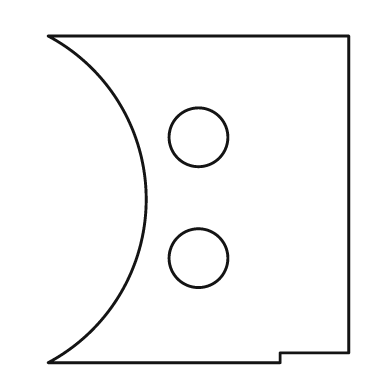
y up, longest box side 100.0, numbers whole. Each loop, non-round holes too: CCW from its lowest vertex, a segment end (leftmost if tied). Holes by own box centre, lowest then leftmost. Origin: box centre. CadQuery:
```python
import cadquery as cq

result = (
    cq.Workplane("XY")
    .moveTo(-46.0, -50.0)
    .lineTo(25.0, -50.0)
    .lineTo(25.0, -47.0)
    .lineTo(46.0, -47.0)
    .lineTo(46.0, 50.0)
    .lineTo(-46.0, 50.0)
    .threePointArc((-16.0, 0.0), (-46.0, -50.0))
    .close()
    .moveTo(0.0, -18.0)
    .circle(9.0)
    .moveTo(0.0, 19.0)
    .circle(9.0)
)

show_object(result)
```